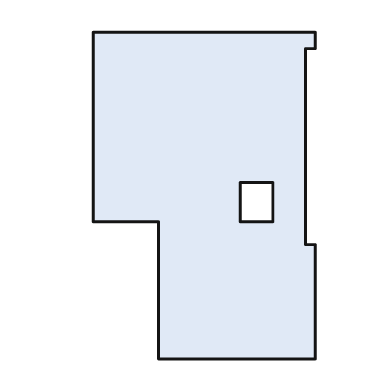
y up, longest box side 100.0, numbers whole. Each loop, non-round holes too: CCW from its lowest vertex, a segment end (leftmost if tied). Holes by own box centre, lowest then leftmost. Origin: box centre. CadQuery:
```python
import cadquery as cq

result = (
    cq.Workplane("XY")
    .moveTo(-14.0, -50.0)
    .lineTo(34.0, -50.0)
    .lineTo(34.0, -15.0)
    .lineTo(31.0, -15.0)
    .lineTo(31.0, 45.0)
    .lineTo(34.0, 45.0)
    .lineTo(34.0, 50.0)
    .lineTo(-34.0, 50.0)
    .lineTo(-34.0, -8.0)
    .lineTo(-14.0, -8.0)
    .close()
    .moveTo(11.0, -8.0)
    .lineTo(21.0, -8.0)
    .lineTo(21.0, 4.0)
    .lineTo(11.0, 4.0)
    .close()
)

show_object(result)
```